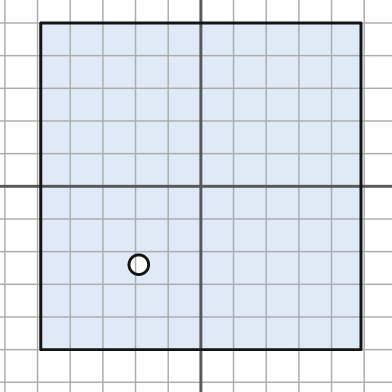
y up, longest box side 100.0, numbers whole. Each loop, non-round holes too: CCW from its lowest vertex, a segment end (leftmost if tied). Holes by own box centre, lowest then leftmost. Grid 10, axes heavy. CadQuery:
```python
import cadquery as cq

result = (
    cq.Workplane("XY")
    .moveTo(-49.0, -50.0)
    .lineTo(49.0, -50.0)
    .lineTo(49.0, 50.0)
    .lineTo(-49.0, 50.0)
    .close()
    .moveTo(-19.0, -24.0)
    .circle(3.0)
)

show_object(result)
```